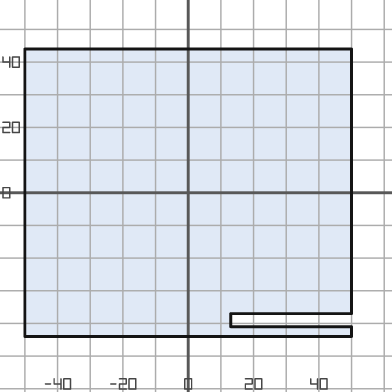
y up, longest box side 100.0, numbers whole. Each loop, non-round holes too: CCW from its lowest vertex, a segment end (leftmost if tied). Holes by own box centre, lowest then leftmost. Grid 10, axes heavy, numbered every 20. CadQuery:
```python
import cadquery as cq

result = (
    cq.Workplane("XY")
    .moveTo(-50.0, -44.0)
    .lineTo(50.0, -44.0)
    .lineTo(50.0, -41.0)
    .lineTo(13.0, -41.0)
    .lineTo(13.0, -37.0)
    .lineTo(50.0, -37.0)
    .lineTo(50.0, 44.0)
    .lineTo(-50.0, 44.0)
    .close()
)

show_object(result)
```